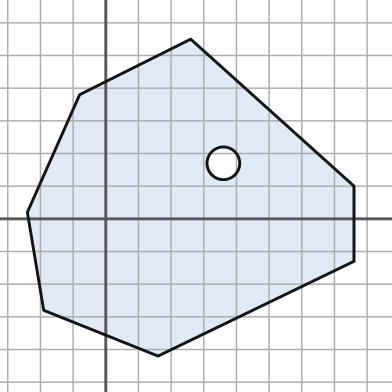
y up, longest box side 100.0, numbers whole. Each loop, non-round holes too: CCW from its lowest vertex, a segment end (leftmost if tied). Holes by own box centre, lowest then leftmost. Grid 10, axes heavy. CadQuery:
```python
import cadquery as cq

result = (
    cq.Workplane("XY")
    .moveTo(16.0, -42.0)
    .lineTo(76.0, -13.0)
    .lineTo(76.0, 10.0)
    .lineTo(26.0, 55.0)
    .lineTo(-8.0, 38.0)
    .lineTo(-24.0, 2.0)
    .lineTo(-19.0, -28.0)
    .close()
    .moveTo(36.0, 17.0)
    .circle(5.0)
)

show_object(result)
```